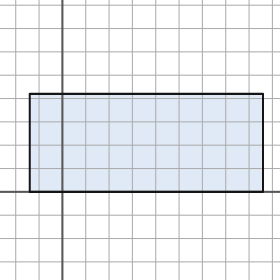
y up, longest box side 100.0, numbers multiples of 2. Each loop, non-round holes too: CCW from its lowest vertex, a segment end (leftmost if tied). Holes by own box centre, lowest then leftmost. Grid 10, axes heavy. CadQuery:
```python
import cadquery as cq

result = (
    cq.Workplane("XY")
    .moveTo(-14.0, 0.0)
    .lineTo(86.0, 0.0)
    .lineTo(86.0, 42.0)
    .lineTo(-14.0, 42.0)
    .close()
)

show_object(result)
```